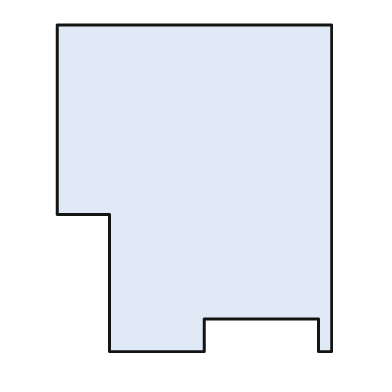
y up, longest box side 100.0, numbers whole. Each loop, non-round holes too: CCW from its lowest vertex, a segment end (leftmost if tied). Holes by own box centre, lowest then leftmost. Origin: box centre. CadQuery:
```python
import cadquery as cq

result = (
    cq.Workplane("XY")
    .moveTo(-26.0, -50.0)
    .lineTo(3.0, -50.0)
    .lineTo(3.0, -40.0)
    .lineTo(38.0, -40.0)
    .lineTo(38.0, -50.0)
    .lineTo(42.0, -50.0)
    .lineTo(42.0, 50.0)
    .lineTo(-42.0, 50.0)
    .lineTo(-42.0, -8.0)
    .lineTo(-26.0, -8.0)
    .close()
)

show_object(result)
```